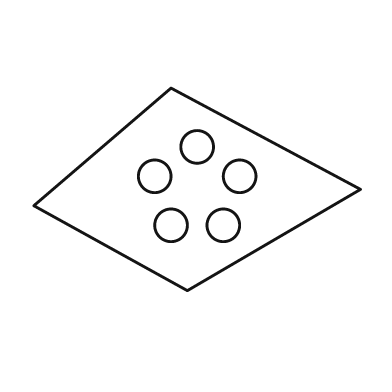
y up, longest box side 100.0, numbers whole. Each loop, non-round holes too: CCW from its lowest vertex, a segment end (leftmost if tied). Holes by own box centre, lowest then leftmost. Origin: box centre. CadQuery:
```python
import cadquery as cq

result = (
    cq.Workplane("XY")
    .moveTo(-3.0, -31.0)
    .lineTo(50.0, 0.0)
    .lineTo(-8.0, 31.0)
    .lineTo(-50.0, -5.0)
    .close()
    .moveTo(-8.0, -11.0)
    .circle(5.0)
    .moveTo(8.0, -11.0)
    .circle(5.0)
    .moveTo(-13.0, 4.0)
    .circle(5.0)
    .moveTo(13.0, 4.0)
    .circle(5.0)
    .moveTo(0.0, 13.0)
    .circle(5.0)
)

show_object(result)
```